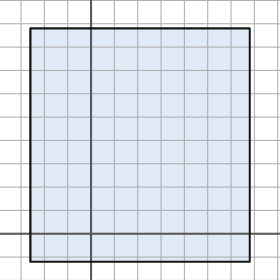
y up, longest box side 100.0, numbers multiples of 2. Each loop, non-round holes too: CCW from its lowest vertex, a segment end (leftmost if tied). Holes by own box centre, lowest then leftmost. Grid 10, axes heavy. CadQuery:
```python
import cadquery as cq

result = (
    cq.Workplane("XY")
    .moveTo(-26.0, -12.0)
    .lineTo(68.0, -12.0)
    .lineTo(68.0, 88.0)
    .lineTo(-26.0, 88.0)
    .close()
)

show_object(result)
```